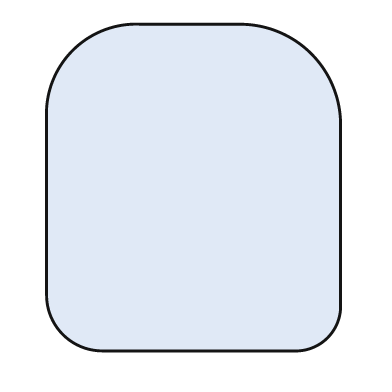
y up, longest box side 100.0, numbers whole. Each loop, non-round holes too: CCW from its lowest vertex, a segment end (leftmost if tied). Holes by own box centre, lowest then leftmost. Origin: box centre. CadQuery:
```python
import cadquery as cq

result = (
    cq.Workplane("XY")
    .moveTo(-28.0, -50.0)
    .lineTo(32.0, -50.0)
    .threePointArc((41.0, -46.0), (45.0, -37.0))
    .lineTo(45.0, 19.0)
    .threePointArc((36.0, 41.0), (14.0, 50.0))
    .lineTo(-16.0, 50.0)
    .threePointArc((-37.0, 42.0), (-45.0, 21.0))
    .lineTo(-45.0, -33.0)
    .threePointArc((-40.0, -45.0), (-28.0, -50.0))
    .close()
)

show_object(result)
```